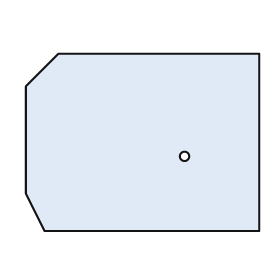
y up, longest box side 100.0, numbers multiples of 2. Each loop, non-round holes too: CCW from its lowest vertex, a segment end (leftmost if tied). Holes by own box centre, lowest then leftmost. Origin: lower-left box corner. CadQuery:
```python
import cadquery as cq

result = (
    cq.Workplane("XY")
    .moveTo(8.0, 0.0)
    .lineTo(100.0, 0.0)
    .lineTo(100.0, 76.0)
    .lineTo(14.0, 76.0)
    .lineTo(0.0, 62.0)
    .lineTo(0.0, 16.0)
    .close()
    .moveTo(68.0, 32.0)
    .circle(2.0)
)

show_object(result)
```